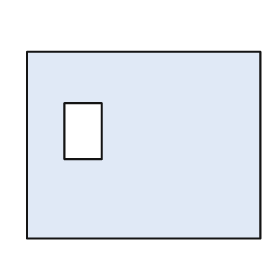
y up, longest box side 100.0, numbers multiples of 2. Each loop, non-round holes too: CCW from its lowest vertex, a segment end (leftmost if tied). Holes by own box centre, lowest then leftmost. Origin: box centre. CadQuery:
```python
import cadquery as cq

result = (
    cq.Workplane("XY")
    .moveTo(-50.0, -40.0)
    .lineTo(50.0, -40.0)
    .lineTo(50.0, 40.0)
    .lineTo(-50.0, 40.0)
    .close()
    .moveTo(-34.0, -6.0)
    .lineTo(-18.0, -6.0)
    .lineTo(-18.0, 18.0)
    .lineTo(-34.0, 18.0)
    .close()
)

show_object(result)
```